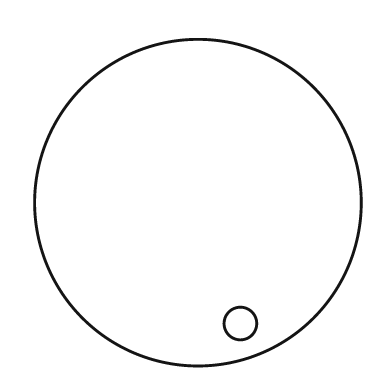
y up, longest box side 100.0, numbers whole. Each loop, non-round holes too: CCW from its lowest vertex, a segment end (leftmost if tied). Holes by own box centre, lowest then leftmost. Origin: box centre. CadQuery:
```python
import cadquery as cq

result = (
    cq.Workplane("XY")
    .moveTo(0.0, 0.0)
    .circle(50.0)
    .moveTo(13.0, -37.0)
    .circle(5.0)
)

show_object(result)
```